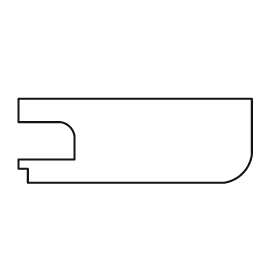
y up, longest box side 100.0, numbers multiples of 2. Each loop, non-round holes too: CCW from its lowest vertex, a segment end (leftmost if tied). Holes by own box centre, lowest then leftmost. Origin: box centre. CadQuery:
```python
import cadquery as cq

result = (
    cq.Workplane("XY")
    .moveTo(-46.0, -18.0)
    .lineTo(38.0, -18.0)
    .threePointArc((46.0, -14.0), (50.0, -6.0))
    .lineTo(50.0, 18.0)
    .lineTo(-50.0, 18.0)
    .lineTo(-50.0, 8.0)
    .lineTo(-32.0, 8.0)
    .threePointArc((-28.0, 6.0), (-26.0, 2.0))
    .lineTo(-26.0, -8.0)
    .lineTo(-50.0, -8.0)
    .lineTo(-50.0, -12.0)
    .lineTo(-46.0, -12.0)
    .close()
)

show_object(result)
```